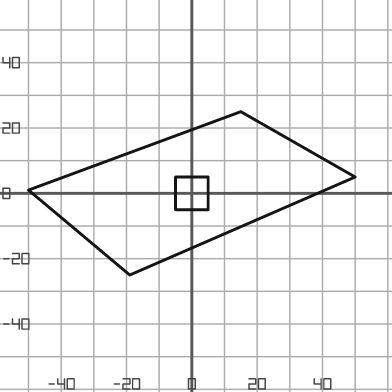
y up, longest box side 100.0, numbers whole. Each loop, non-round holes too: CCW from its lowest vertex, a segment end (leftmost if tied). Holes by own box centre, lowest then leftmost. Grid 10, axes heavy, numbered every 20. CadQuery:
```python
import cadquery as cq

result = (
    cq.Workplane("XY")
    .moveTo(-19.0, -25.0)
    .lineTo(50.0, 5.0)
    .lineTo(15.0, 25.0)
    .lineTo(-50.0, 1.0)
    .close()
    .moveTo(-5.0, -5.0)
    .lineTo(5.0, -5.0)
    .lineTo(5.0, 5.0)
    .lineTo(-5.0, 5.0)
    .close()
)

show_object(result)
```